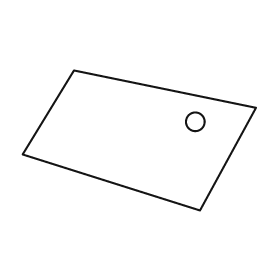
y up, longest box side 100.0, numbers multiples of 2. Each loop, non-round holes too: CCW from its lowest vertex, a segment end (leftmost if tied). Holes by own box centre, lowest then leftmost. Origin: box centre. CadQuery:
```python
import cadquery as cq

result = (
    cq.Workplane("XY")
    .moveTo(26.0, -30.0)
    .lineTo(50.0, 14.0)
    .lineTo(-28.0, 30.0)
    .lineTo(-50.0, -6.0)
    .close()
    .moveTo(24.0, 8.0)
    .circle(4.0)
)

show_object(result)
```